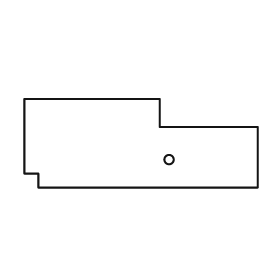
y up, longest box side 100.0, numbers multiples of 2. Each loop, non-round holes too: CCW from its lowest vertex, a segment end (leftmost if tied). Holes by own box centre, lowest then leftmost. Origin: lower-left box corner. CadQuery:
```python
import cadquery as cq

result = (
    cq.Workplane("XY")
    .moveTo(6.0, 0.0)
    .lineTo(100.0, 0.0)
    .lineTo(100.0, 26.0)
    .lineTo(58.0, 26.0)
    .lineTo(58.0, 38.0)
    .lineTo(0.0, 38.0)
    .lineTo(0.0, 6.0)
    .lineTo(6.0, 6.0)
    .close()
    .moveTo(62.0, 12.0)
    .circle(2.0)
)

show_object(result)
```